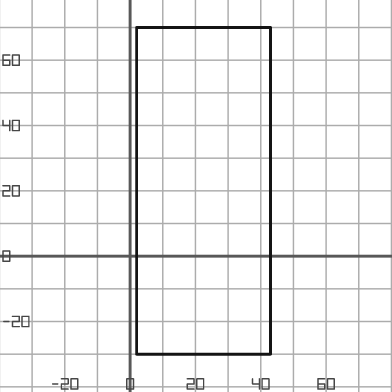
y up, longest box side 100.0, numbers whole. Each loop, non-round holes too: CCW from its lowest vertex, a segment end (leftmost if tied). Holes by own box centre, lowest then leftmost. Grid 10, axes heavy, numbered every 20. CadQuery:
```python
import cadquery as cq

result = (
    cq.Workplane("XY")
    .moveTo(2.0, -30.0)
    .lineTo(43.0, -30.0)
    .lineTo(43.0, 70.0)
    .lineTo(2.0, 70.0)
    .close()
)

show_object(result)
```